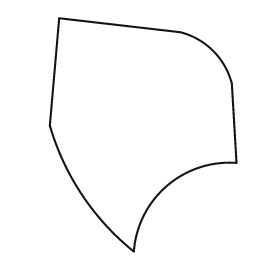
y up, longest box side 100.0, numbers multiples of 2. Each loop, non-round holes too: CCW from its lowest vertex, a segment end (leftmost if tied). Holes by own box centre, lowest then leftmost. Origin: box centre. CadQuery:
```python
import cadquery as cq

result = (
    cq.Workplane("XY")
    .moveTo(-4.0, -50.0)
    .threePointArc((10.0, -22.0), (40.0, -12.0))
    .lineTo(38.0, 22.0)
    .threePointArc((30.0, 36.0), (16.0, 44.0))
    .lineTo(-36.0, 50.0)
    .lineTo(-40.0, 4.0)
    .threePointArc((-26.0, -26.0), (-4.0, -50.0))
    .close()
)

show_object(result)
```